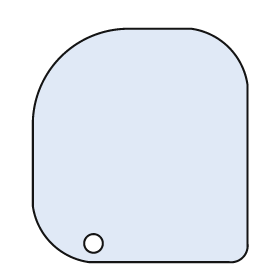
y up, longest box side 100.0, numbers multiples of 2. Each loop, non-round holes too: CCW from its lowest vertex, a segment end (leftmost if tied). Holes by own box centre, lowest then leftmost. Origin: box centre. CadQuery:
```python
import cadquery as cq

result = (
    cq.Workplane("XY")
    .moveTo(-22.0, -50.0)
    .lineTo(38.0, -50.0)
    .threePointArc((44.0, -48.0), (46.0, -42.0))
    .lineTo(46.0, 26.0)
    .threePointArc((38.0, 42.0), (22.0, 50.0))
    .lineTo(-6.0, 50.0)
    .threePointArc((-34.0, 38.0), (-46.0, 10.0))
    .lineTo(-46.0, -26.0)
    .threePointArc((-38.0, -42.0), (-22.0, -50.0))
    .close()
    .moveTo(-20.0, -42.0)
    .circle(4.0)
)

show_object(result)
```